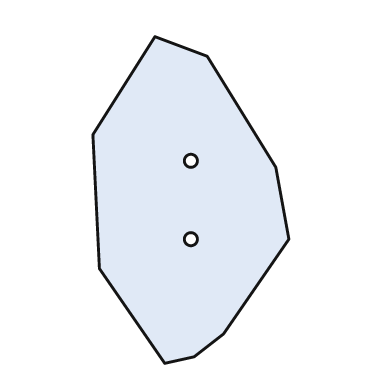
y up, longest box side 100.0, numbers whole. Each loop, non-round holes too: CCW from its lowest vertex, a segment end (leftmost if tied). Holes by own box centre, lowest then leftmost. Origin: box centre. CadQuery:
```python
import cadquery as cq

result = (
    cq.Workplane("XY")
    .moveTo(-8.0, -50.0)
    .lineTo(1.0, -48.0)
    .lineTo(10.0, -41.0)
    .lineTo(30.0, -12.0)
    .lineTo(26.0, 10.0)
    .lineTo(5.0, 44.0)
    .lineTo(-11.0, 50.0)
    .lineTo(-30.0, 20.0)
    .lineTo(-28.0, -21.0)
    .close()
    .moveTo(0.0, -12.0)
    .circle(2.0)
    .moveTo(0.0, 12.0)
    .circle(2.0)
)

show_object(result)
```